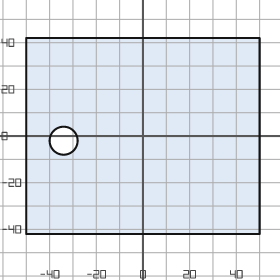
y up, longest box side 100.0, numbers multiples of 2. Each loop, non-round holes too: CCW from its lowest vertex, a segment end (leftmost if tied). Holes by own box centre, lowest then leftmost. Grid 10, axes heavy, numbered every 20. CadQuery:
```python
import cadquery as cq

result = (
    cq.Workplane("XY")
    .moveTo(-50.0, -42.0)
    .lineTo(50.0, -42.0)
    .lineTo(50.0, 42.0)
    .lineTo(-50.0, 42.0)
    .close()
    .moveTo(-34.0, -2.0)
    .circle(6.0)
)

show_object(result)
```